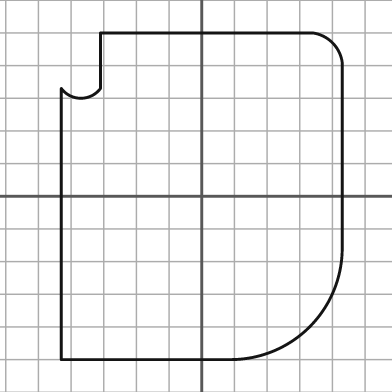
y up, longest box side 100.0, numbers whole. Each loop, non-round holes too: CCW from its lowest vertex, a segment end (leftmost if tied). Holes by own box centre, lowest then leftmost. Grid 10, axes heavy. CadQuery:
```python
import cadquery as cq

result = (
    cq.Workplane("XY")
    .moveTo(-43.0, -50.0)
    .lineTo(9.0, -50.0)
    .threePointArc((33.0, -40.0), (43.0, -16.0))
    .lineTo(43.0, 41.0)
    .threePointArc((40.0, 47.0), (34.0, 50.0))
    .lineTo(-31.0, 50.0)
    .lineTo(-31.0, 33.0)
    .threePointArc((-37.0, 30.0), (-43.0, 33.0))
    .close()
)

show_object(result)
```